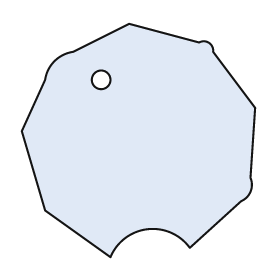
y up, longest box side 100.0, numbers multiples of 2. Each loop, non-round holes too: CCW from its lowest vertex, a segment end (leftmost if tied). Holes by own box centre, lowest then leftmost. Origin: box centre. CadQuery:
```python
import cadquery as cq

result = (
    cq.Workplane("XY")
    .moveTo(-12.0, -50.0)
    .threePointArc((4.0, -38.0), (22.0, -46.0))
    .lineTo(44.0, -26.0)
    .threePointArc((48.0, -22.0), (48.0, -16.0))
    .lineTo(50.0, 14.0)
    .lineTo(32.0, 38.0)
    .threePointArc((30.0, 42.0), (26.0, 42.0))
    .lineTo(-4.0, 50.0)
    .lineTo(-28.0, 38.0)
    .threePointArc((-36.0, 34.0), (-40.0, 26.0))
    .lineTo(-50.0, 4.0)
    .lineTo(-40.0, -30.0)
    .close()
    .moveTo(-16.0, 26.0)
    .circle(4.0)
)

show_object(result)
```